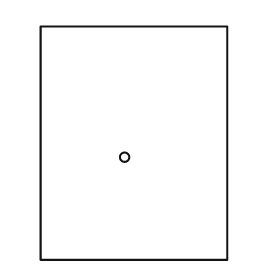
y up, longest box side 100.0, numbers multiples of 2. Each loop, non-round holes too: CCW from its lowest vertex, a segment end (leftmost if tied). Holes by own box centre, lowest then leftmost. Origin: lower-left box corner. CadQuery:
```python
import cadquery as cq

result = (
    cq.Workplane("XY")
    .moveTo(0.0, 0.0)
    .lineTo(80.0, 0.0)
    .lineTo(80.0, 100.0)
    .lineTo(0.0, 100.0)
    .close()
    .moveTo(36.0, 44.0)
    .circle(2.0)
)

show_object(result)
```